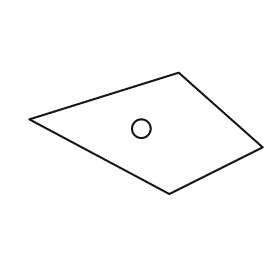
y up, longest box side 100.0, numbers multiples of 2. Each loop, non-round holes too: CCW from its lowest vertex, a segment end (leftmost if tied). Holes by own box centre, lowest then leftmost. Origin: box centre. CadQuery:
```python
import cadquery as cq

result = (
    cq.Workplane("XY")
    .moveTo(10.0, -26.0)
    .lineTo(50.0, -6.0)
    .lineTo(14.0, 26.0)
    .lineTo(-50.0, 6.0)
    .close()
    .moveTo(-2.0, 2.0)
    .circle(4.0)
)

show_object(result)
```